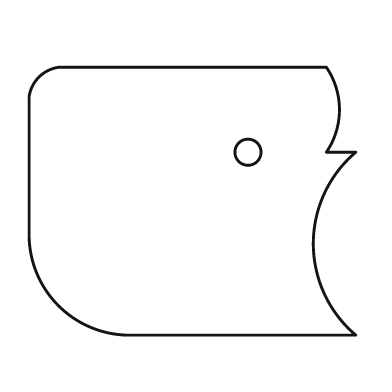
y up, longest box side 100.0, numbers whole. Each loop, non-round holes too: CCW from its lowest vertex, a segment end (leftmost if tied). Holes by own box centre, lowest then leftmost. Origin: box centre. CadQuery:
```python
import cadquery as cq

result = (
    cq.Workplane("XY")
    .moveTo(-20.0, -41.0)
    .lineTo(50.0, -41.0)
    .threePointArc((37.0, -13.0), (50.0, 15.0))
    .lineTo(41.0, 15.0)
    .threePointArc((45.0, 28.0), (41.0, 41.0))
    .lineTo(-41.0, 41.0)
    .threePointArc((-47.0, 38.0), (-50.0, 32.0))
    .lineTo(-50.0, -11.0)
    .threePointArc((-41.0, -32.0), (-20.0, -41.0))
    .close()
    .moveTo(17.0, 15.0)
    .circle(4.0)
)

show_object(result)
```